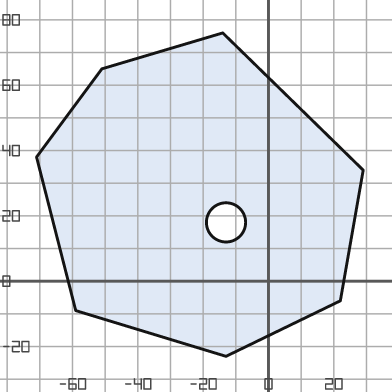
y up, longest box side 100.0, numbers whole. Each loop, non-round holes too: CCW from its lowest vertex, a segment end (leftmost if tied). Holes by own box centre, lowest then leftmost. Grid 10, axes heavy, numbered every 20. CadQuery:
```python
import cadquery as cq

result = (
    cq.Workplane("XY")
    .moveTo(-13.0, -23.0)
    .lineTo(22.0, -6.0)
    .lineTo(29.0, 34.0)
    .lineTo(-14.0, 76.0)
    .lineTo(-51.0, 65.0)
    .lineTo(-71.0, 38.0)
    .lineTo(-59.0, -9.0)
    .close()
    .moveTo(-13.0, 18.0)
    .circle(6.0)
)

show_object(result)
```